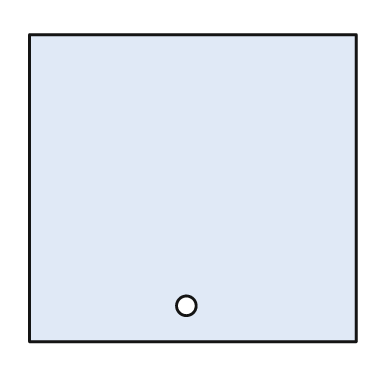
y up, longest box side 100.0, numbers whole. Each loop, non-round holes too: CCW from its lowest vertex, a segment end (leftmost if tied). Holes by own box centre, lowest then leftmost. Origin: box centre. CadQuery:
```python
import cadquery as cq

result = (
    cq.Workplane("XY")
    .moveTo(-50.0, -47.0)
    .lineTo(50.0, -47.0)
    .lineTo(50.0, 47.0)
    .lineTo(-50.0, 47.0)
    .close()
    .moveTo(-2.0, -36.0)
    .circle(3.0)
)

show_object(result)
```